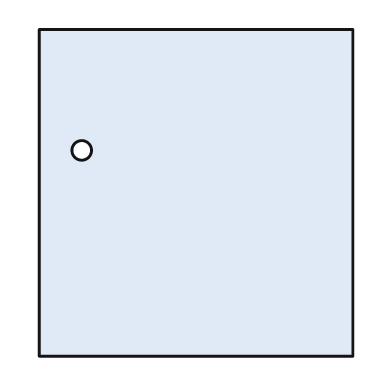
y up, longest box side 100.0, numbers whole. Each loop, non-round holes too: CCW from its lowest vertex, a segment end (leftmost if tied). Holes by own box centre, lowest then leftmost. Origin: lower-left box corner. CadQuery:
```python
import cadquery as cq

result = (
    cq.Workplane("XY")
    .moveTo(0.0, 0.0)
    .lineTo(96.0, 0.0)
    .lineTo(96.0, 100.0)
    .lineTo(0.0, 100.0)
    .close()
    .moveTo(13.0, 63.0)
    .circle(3.0)
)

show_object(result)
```